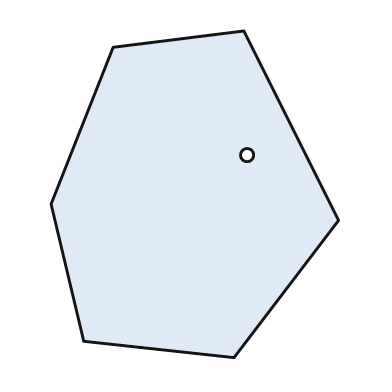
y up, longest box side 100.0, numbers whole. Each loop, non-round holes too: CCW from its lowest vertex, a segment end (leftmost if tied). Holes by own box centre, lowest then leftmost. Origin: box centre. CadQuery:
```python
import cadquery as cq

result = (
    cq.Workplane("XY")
    .moveTo(12.0, -50.0)
    .lineTo(44.0, -8.0)
    .lineTo(15.0, 50.0)
    .lineTo(-25.0, 45.0)
    .lineTo(-44.0, -3.0)
    .lineTo(-34.0, -45.0)
    .close()
    .moveTo(16.0, 12.0)
    .circle(2.0)
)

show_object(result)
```